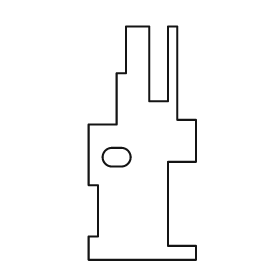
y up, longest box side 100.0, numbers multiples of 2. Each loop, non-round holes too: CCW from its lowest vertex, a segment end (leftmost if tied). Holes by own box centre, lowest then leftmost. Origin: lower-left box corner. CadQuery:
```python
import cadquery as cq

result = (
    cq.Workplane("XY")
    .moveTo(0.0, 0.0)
    .lineTo(46.0, 0.0)
    .lineTo(46.0, 6.0)
    .lineTo(34.0, 6.0)
    .lineTo(34.0, 42.0)
    .lineTo(46.0, 42.0)
    .lineTo(46.0, 60.0)
    .lineTo(38.0, 60.0)
    .lineTo(38.0, 100.0)
    .lineTo(34.0, 100.0)
    .lineTo(34.0, 68.0)
    .lineTo(26.0, 68.0)
    .lineTo(26.0, 100.0)
    .lineTo(16.0, 100.0)
    .lineTo(16.0, 80.0)
    .lineTo(12.0, 80.0)
    .lineTo(12.0, 58.0)
    .lineTo(0.0, 58.0)
    .lineTo(0.0, 32.0)
    .lineTo(4.0, 32.0)
    .lineTo(4.0, 10.0)
    .lineTo(0.0, 10.0)
    .close()
    .moveTo(10.0, 40.0)
    .lineTo(14.0, 40.0)
    .threePointArc((18.0, 44.0), (14.0, 48.0))
    .lineTo(10.0, 48.0)
    .threePointArc((6.0, 44.0), (10.0, 40.0))
    .close()
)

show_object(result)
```